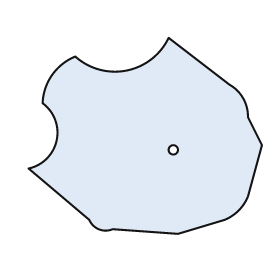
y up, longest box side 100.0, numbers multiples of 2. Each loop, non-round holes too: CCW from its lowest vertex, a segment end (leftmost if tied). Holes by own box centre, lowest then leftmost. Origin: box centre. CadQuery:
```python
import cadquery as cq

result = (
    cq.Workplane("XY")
    .moveTo(14.0, -42.0)
    .lineTo(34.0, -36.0)
    .threePointArc((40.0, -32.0), (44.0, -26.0))
    .lineTo(50.0, -4.0)
    .lineTo(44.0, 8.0)
    .threePointArc((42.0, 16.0), (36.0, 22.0))
    .lineTo(10.0, 42.0)
    .threePointArc((-8.0, 28.0), (-30.0, 34.0))
    .threePointArc((-40.0, 26.0), (-44.0, 14.0))
    .threePointArc((-38.0, -2.0), (-50.0, -14.0))
    .lineTo(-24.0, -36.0)
    .threePointArc((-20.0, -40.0), (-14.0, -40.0))
    .close()
    .moveTo(12.0, -6.0)
    .circle(2.0)
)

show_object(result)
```